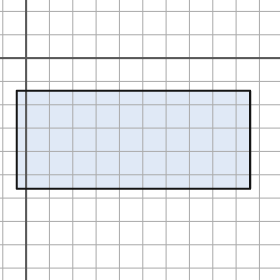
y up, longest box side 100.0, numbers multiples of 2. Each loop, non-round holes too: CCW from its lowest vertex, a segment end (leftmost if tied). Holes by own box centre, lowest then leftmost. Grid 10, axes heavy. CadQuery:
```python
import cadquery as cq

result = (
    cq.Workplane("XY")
    .moveTo(-4.0, -56.0)
    .lineTo(96.0, -56.0)
    .lineTo(96.0, -14.0)
    .lineTo(-4.0, -14.0)
    .close()
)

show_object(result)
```